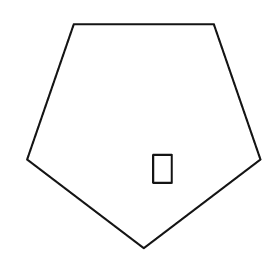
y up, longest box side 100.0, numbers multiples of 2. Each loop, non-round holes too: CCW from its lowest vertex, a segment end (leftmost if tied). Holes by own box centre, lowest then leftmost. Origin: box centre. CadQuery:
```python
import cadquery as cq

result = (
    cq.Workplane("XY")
    .moveTo(0.0, -48.0)
    .lineTo(50.0, -10.0)
    .lineTo(30.0, 48.0)
    .lineTo(-30.0, 48.0)
    .lineTo(-50.0, -10.0)
    .close()
    .moveTo(4.0, -20.0)
    .lineTo(12.0, -20.0)
    .lineTo(12.0, -8.0)
    .lineTo(4.0, -8.0)
    .close()
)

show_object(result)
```